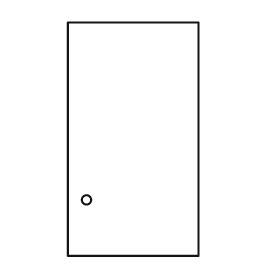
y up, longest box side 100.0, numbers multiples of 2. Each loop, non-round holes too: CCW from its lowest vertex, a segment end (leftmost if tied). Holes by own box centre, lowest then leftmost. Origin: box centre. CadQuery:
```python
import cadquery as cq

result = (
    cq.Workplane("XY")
    .moveTo(-28.0, -50.0)
    .lineTo(28.0, -50.0)
    .lineTo(28.0, 50.0)
    .lineTo(-28.0, 50.0)
    .close()
    .moveTo(-20.0, -26.0)
    .circle(2.0)
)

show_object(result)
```